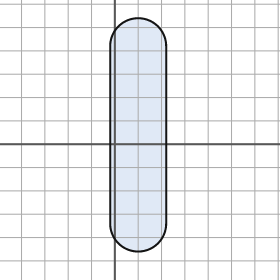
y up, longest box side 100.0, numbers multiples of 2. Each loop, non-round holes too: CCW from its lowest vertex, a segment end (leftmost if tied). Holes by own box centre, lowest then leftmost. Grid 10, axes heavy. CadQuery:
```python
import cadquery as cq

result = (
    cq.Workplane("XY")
    .moveTo(-2.0, -34.0)
    .threePointArc((10.0, -46.0), (22.0, -34.0))
    .lineTo(22.0, 42.0)
    .threePointArc((10.0, 54.0), (-2.0, 42.0))
    .close()
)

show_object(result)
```